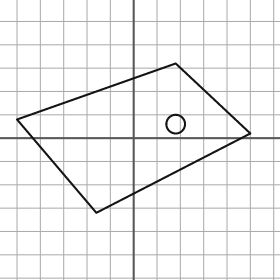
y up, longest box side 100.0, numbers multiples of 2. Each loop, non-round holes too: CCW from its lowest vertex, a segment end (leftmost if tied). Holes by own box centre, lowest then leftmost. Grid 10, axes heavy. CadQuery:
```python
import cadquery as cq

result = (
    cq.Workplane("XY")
    .moveTo(-16.0, -32.0)
    .lineTo(50.0, 2.0)
    .lineTo(18.0, 32.0)
    .lineTo(-50.0, 8.0)
    .close()
    .moveTo(18.0, 6.0)
    .circle(4.0)
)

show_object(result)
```